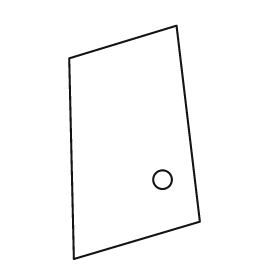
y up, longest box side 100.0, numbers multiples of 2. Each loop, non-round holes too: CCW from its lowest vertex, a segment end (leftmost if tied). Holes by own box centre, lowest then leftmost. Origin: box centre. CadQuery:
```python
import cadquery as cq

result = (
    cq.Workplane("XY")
    .moveTo(-26.0, -50.0)
    .lineTo(28.0, -34.0)
    .lineTo(18.0, 50.0)
    .lineTo(-28.0, 36.0)
    .close()
    .moveTo(12.0, -16.0)
    .circle(4.0)
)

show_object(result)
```